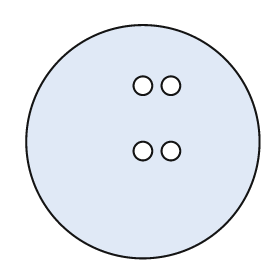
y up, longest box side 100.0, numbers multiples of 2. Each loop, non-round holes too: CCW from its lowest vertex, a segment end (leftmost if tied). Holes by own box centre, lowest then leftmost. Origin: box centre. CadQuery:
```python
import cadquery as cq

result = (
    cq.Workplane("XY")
    .moveTo(0.0, 0.0)
    .circle(50.0)
    .moveTo(0.0, -4.0)
    .circle(4.0)
    .moveTo(12.0, -4.0)
    .circle(4.0)
    .moveTo(0.0, 24.0)
    .circle(4.0)
    .moveTo(12.0, 24.0)
    .circle(4.0)
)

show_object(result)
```